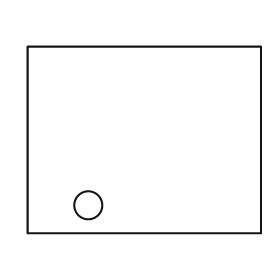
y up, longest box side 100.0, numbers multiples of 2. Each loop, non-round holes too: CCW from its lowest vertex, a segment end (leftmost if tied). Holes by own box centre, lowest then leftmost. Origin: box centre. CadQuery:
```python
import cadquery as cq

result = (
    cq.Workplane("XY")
    .moveTo(-50.0, -40.0)
    .lineTo(50.0, -40.0)
    .lineTo(50.0, 40.0)
    .lineTo(-50.0, 40.0)
    .close()
    .moveTo(-24.0, -28.0)
    .circle(6.0)
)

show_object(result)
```